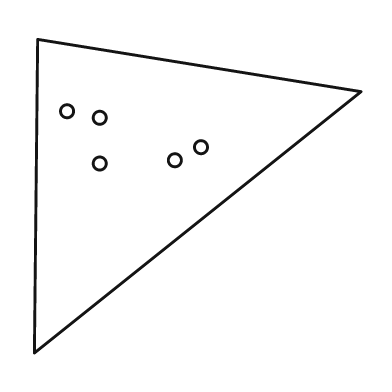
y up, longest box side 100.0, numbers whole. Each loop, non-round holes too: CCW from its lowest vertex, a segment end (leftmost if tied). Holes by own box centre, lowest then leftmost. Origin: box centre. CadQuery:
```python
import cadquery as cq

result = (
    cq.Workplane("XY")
    .moveTo(-50.0, -48.0)
    .lineTo(50.0, 32.0)
    .lineTo(-49.0, 48.0)
    .close()
    .moveTo(-30.0, 10.0)
    .circle(2.0)
    .moveTo(-7.0, 11.0)
    .circle(2.0)
    .moveTo(1.0, 15.0)
    .circle(2.0)
    .moveTo(-30.0, 24.0)
    .circle(2.0)
    .moveTo(-40.0, 26.0)
    .circle(2.0)
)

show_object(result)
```